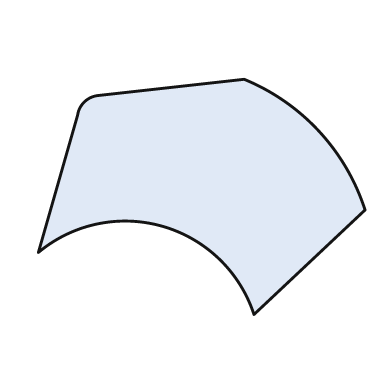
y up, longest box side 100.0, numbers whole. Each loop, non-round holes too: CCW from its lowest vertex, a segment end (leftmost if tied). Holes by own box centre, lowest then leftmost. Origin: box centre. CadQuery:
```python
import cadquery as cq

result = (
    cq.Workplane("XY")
    .moveTo(16.0, -36.0)
    .lineTo(50.0, -4.0)
    .threePointArc((36.0, 20.0), (13.0, 36.0))
    .lineTo(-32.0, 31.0)
    .threePointArc((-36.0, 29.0), (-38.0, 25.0))
    .lineTo(-50.0, -17.0)
    .threePointArc((-12.0, -9.0), (16.0, -36.0))
    .close()
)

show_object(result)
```